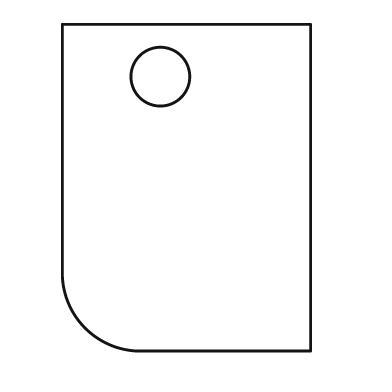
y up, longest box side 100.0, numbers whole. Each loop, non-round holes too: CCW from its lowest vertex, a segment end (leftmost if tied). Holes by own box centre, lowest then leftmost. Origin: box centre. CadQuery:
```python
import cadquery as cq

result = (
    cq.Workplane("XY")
    .moveTo(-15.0, -50.0)
    .lineTo(38.0, -50.0)
    .lineTo(38.0, 50.0)
    .lineTo(-38.0, 50.0)
    .lineTo(-38.0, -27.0)
    .threePointArc((-31.0, -43.0), (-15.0, -50.0))
    .close()
    .moveTo(-8.0, 34.0)
    .circle(9.0)
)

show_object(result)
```